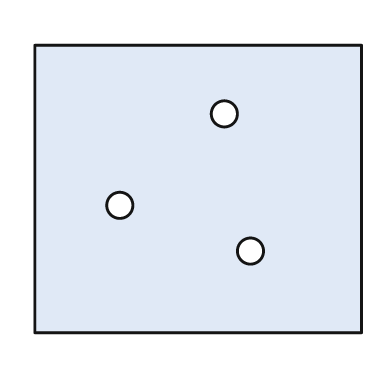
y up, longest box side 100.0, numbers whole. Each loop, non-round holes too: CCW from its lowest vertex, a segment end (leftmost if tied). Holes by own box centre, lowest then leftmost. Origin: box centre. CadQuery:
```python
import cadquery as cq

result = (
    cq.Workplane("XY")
    .moveTo(-50.0, -44.0)
    .lineTo(50.0, -44.0)
    .lineTo(50.0, 44.0)
    .lineTo(-50.0, 44.0)
    .close()
    .moveTo(16.0, -19.0)
    .circle(4.0)
    .moveTo(-24.0, -5.0)
    .circle(4.0)
    .moveTo(8.0, 23.0)
    .circle(4.0)
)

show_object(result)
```